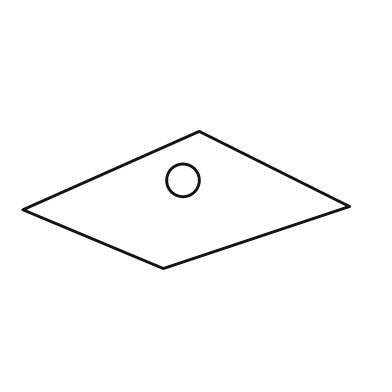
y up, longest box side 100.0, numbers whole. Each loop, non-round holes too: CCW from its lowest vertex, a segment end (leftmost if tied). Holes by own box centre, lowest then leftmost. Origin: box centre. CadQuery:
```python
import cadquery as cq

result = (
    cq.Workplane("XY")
    .moveTo(-7.0, -21.0)
    .lineTo(50.0, -2.0)
    .lineTo(4.0, 21.0)
    .lineTo(-50.0, -3.0)
    .close()
    .moveTo(-1.0, 6.0)
    .circle(5.0)
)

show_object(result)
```